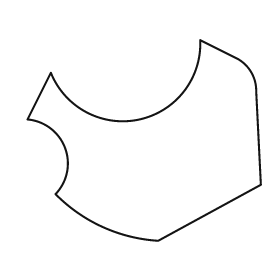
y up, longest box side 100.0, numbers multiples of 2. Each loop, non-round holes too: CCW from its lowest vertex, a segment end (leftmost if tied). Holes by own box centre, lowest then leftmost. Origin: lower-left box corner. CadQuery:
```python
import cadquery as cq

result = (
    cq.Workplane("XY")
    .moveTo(56.0, 0.0)
    .lineTo(100.0, 24.0)
    .lineTo(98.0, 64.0)
    .threePointArc((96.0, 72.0), (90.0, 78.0))
    .lineTo(74.0, 86.0)
    .threePointArc((48.0, 52.0), (10.0, 72.0))
    .lineTo(0.0, 52.0)
    .threePointArc((16.0, 40.0), (12.0, 20.0))
    .threePointArc((32.0, 6.0), (56.0, 0.0))
    .close()
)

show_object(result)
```